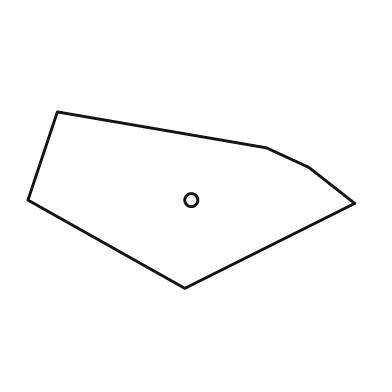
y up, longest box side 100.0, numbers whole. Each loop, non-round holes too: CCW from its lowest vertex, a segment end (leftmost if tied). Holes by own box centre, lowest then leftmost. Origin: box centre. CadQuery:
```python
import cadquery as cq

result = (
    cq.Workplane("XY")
    .moveTo(-2.0, -27.0)
    .lineTo(50.0, -1.0)
    .lineTo(36.0, 10.0)
    .lineTo(23.0, 16.0)
    .lineTo(-41.0, 27.0)
    .lineTo(-50.0, 0.0)
    .close()
    .moveTo(0.0, 0.0)
    .circle(2.0)
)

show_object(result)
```